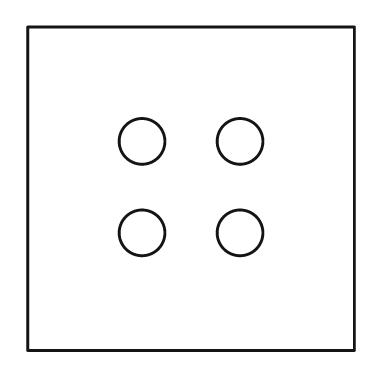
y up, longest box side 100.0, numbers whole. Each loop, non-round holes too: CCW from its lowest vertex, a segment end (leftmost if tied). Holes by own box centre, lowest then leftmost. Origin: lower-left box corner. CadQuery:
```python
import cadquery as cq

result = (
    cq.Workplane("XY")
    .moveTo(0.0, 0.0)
    .lineTo(100.0, 0.0)
    .lineTo(100.0, 99.0)
    .lineTo(0.0, 99.0)
    .close()
    .moveTo(35.0, 36.0)
    .circle(7.0)
    .moveTo(65.0, 36.0)
    .circle(7.0)
    .moveTo(35.0, 64.0)
    .circle(7.0)
    .moveTo(65.0, 64.0)
    .circle(7.0)
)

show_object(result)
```